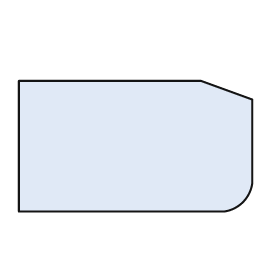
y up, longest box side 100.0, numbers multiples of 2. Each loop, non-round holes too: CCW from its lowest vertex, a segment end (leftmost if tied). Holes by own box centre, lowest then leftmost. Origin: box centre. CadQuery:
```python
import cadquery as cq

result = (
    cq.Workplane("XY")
    .moveTo(-50.0, -28.0)
    .lineTo(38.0, -28.0)
    .threePointArc((46.0, -24.0), (50.0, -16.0))
    .lineTo(50.0, 20.0)
    .lineTo(28.0, 28.0)
    .lineTo(-50.0, 28.0)
    .close()
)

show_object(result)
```